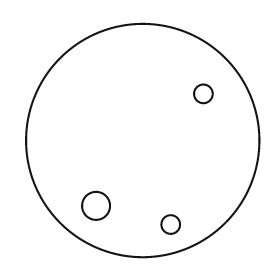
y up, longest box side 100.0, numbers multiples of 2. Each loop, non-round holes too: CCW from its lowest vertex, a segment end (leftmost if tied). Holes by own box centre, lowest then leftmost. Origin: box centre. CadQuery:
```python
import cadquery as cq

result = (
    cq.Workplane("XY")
    .moveTo(0.0, 0.0)
    .circle(50.0)
    .moveTo(12.0, -36.0)
    .circle(4.0)
    .moveTo(-20.0, -28.0)
    .circle(6.0)
    .moveTo(26.0, 20.0)
    .circle(4.0)
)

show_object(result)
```